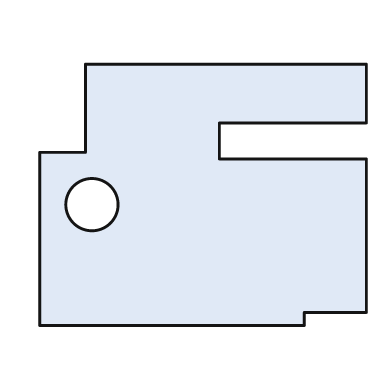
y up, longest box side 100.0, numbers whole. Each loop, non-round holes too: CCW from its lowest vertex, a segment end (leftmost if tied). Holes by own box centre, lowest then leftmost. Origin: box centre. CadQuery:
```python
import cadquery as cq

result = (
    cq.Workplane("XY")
    .moveTo(-50.0, -40.0)
    .lineTo(31.0, -40.0)
    .lineTo(31.0, -36.0)
    .lineTo(50.0, -36.0)
    .lineTo(50.0, 11.0)
    .lineTo(5.0, 11.0)
    .lineTo(5.0, 22.0)
    .lineTo(50.0, 22.0)
    .lineTo(50.0, 40.0)
    .lineTo(-36.0, 40.0)
    .lineTo(-36.0, 13.0)
    .lineTo(-50.0, 13.0)
    .close()
    .moveTo(-34.0, -3.0)
    .circle(8.0)
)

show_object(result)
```